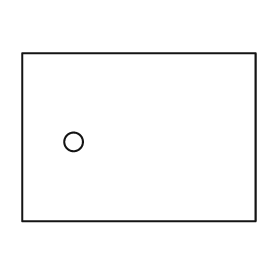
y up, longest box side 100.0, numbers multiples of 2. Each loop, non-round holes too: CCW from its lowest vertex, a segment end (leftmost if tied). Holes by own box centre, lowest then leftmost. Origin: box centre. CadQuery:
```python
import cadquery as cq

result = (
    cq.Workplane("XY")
    .moveTo(-50.0, -36.0)
    .lineTo(50.0, -36.0)
    .lineTo(50.0, 36.0)
    .lineTo(-50.0, 36.0)
    .close()
    .moveTo(-28.0, -2.0)
    .circle(4.0)
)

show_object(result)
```